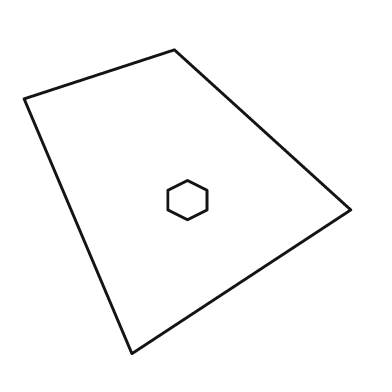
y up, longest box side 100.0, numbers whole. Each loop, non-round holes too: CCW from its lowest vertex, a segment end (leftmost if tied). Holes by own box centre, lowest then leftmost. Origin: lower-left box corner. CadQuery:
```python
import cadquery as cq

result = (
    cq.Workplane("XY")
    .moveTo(33.0, 0.0)
    .lineTo(100.0, 44.0)
    .lineTo(46.0, 93.0)
    .lineTo(0.0, 78.0)
    .close()
    .moveTo(50.0, 41.0)
    .lineTo(56.0, 44.0)
    .lineTo(56.0, 50.0)
    .lineTo(50.0, 53.0)
    .lineTo(44.0, 50.0)
    .lineTo(44.0, 44.0)
    .close()
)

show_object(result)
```